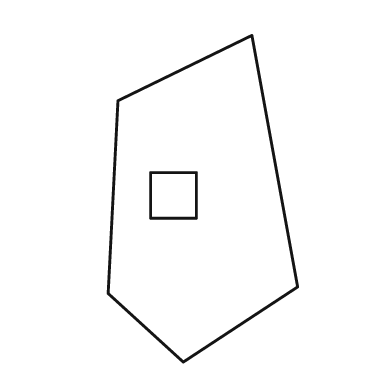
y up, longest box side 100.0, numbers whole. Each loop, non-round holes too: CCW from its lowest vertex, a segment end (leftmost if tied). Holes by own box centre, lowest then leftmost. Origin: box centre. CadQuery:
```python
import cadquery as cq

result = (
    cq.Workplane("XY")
    .moveTo(-6.0, -50.0)
    .lineTo(29.0, -27.0)
    .lineTo(15.0, 50.0)
    .lineTo(-26.0, 30.0)
    .lineTo(-29.0, -29.0)
    .close()
    .moveTo(-16.0, -6.0)
    .lineTo(-2.0, -6.0)
    .lineTo(-2.0, 8.0)
    .lineTo(-16.0, 8.0)
    .close()
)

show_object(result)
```